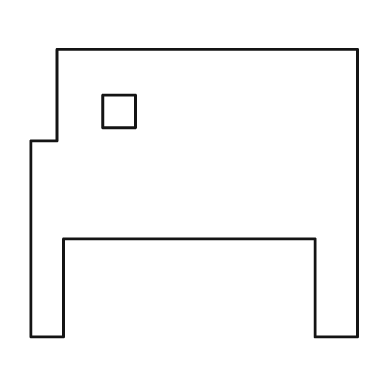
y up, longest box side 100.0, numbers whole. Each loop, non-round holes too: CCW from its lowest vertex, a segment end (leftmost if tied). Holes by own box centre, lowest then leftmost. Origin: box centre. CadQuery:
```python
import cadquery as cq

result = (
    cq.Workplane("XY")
    .moveTo(-50.0, -44.0)
    .lineTo(-40.0, -44.0)
    .lineTo(-40.0, -14.0)
    .lineTo(37.0, -14.0)
    .lineTo(37.0, -44.0)
    .lineTo(50.0, -44.0)
    .lineTo(50.0, 44.0)
    .lineTo(-42.0, 44.0)
    .lineTo(-42.0, 16.0)
    .lineTo(-50.0, 16.0)
    .close()
    .moveTo(-28.0, 20.0)
    .lineTo(-18.0, 20.0)
    .lineTo(-18.0, 30.0)
    .lineTo(-28.0, 30.0)
    .close()
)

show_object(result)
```